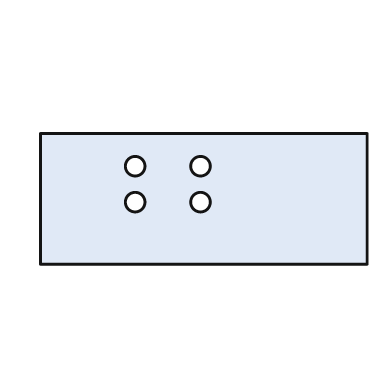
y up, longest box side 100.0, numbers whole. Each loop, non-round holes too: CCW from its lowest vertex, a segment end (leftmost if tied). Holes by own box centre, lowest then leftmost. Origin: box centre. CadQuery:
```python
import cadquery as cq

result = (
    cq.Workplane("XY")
    .moveTo(-50.0, -20.0)
    .lineTo(50.0, -20.0)
    .lineTo(50.0, 20.0)
    .lineTo(-50.0, 20.0)
    .close()
    .moveTo(-21.0, -1.0)
    .circle(3.0)
    .moveTo(-1.0, -1.0)
    .circle(3.0)
    .moveTo(-21.0, 10.0)
    .circle(3.0)
    .moveTo(-1.0, 10.0)
    .circle(3.0)
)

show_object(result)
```